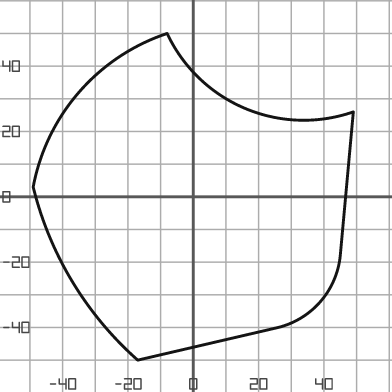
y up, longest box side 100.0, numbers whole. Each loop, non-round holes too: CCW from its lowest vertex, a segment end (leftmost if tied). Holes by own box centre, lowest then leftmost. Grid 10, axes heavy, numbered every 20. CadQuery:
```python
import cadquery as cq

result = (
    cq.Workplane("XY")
    .moveTo(-17.0, -50.0)
    .lineTo(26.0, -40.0)
    .threePointArc((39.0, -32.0), (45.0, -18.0))
    .lineTo(49.0, 26.0)
    .threePointArc((16.0, 27.0), (-8.0, 50.0))
    .threePointArc((-35.0, 32.0), (-49.0, 3.0))
    .threePointArc((-37.0, -26.0), (-17.0, -50.0))
    .close()
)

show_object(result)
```